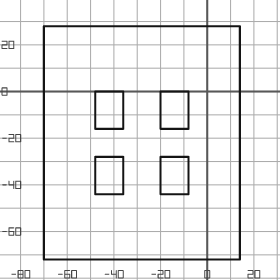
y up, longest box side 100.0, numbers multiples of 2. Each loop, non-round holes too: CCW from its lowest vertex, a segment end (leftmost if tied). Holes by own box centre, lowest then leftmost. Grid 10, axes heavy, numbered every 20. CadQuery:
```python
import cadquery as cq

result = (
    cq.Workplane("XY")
    .moveTo(-70.0, -72.0)
    .lineTo(14.0, -72.0)
    .lineTo(14.0, 28.0)
    .lineTo(-70.0, 28.0)
    .close()
    .moveTo(-48.0, -44.0)
    .lineTo(-36.0, -44.0)
    .lineTo(-36.0, -28.0)
    .lineTo(-48.0, -28.0)
    .close()
    .moveTo(-20.0, -44.0)
    .lineTo(-8.0, -44.0)
    .lineTo(-8.0, -28.0)
    .lineTo(-20.0, -28.0)
    .close()
    .moveTo(-48.0, -16.0)
    .lineTo(-36.0, -16.0)
    .lineTo(-36.0, 0.0)
    .lineTo(-48.0, 0.0)
    .close()
    .moveTo(-20.0, -16.0)
    .lineTo(-8.0, -16.0)
    .lineTo(-8.0, 0.0)
    .lineTo(-20.0, 0.0)
    .close()
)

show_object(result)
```